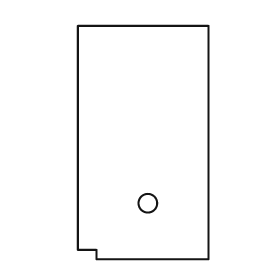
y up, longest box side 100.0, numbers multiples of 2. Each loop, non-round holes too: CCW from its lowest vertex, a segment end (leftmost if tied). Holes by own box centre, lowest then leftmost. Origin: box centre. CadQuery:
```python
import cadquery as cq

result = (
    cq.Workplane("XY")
    .moveTo(-20.0, -50.0)
    .lineTo(28.0, -50.0)
    .lineTo(28.0, 50.0)
    .lineTo(-28.0, 50.0)
    .lineTo(-28.0, -46.0)
    .lineTo(-20.0, -46.0)
    .close()
    .moveTo(2.0, -26.0)
    .circle(4.0)
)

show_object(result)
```